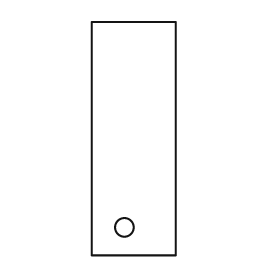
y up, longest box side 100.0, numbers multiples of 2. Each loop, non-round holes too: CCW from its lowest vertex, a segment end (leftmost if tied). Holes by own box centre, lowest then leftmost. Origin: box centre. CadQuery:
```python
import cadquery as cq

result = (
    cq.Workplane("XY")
    .moveTo(-18.0, -50.0)
    .lineTo(18.0, -50.0)
    .lineTo(18.0, 50.0)
    .lineTo(-18.0, 50.0)
    .close()
    .moveTo(-4.0, -38.0)
    .circle(4.0)
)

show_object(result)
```